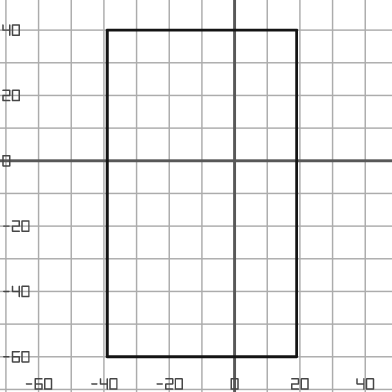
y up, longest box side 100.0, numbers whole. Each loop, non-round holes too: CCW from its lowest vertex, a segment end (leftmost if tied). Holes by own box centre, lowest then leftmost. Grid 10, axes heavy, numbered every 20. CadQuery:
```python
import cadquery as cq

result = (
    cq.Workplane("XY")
    .moveTo(-39.0, -60.0)
    .lineTo(19.0, -60.0)
    .lineTo(19.0, 40.0)
    .lineTo(-39.0, 40.0)
    .close()
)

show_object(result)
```